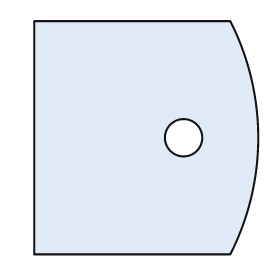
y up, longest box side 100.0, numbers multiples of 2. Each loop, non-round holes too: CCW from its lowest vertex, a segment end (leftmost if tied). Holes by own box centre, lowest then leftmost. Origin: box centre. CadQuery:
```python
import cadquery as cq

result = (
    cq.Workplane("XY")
    .moveTo(-48.0, -50.0)
    .lineTo(36.0, -50.0)
    .threePointArc((48.0, 0.0), (36.0, 50.0))
    .lineTo(-48.0, 50.0)
    .close()
    .moveTo(16.0, 0.0)
    .circle(8.0)
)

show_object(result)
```